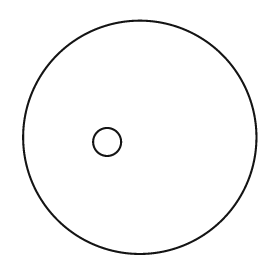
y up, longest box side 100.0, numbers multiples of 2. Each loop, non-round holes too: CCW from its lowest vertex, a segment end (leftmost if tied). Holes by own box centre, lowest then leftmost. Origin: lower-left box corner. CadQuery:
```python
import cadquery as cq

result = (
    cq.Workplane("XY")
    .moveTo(50.0, 50.0)
    .circle(50.0)
    .moveTo(36.0, 48.0)
    .circle(6.0)
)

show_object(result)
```